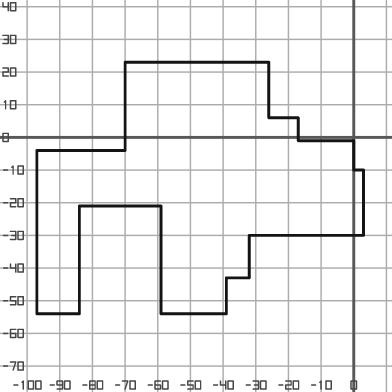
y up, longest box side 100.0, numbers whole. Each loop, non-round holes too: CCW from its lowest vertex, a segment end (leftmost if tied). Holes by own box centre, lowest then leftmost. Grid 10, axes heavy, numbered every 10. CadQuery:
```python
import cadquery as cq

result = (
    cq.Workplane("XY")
    .moveTo(-97.0, -54.0)
    .lineTo(-84.0, -54.0)
    .lineTo(-84.0, -21.0)
    .lineTo(-59.0, -21.0)
    .lineTo(-59.0, -54.0)
    .lineTo(-39.0, -54.0)
    .lineTo(-39.0, -43.0)
    .lineTo(-32.0, -43.0)
    .lineTo(-32.0, -30.0)
    .lineTo(3.0, -30.0)
    .lineTo(3.0, -10.0)
    .lineTo(0.0, -10.0)
    .lineTo(0.0, -1.0)
    .lineTo(-17.0, -1.0)
    .lineTo(-17.0, 6.0)
    .lineTo(-26.0, 6.0)
    .lineTo(-26.0, 23.0)
    .lineTo(-70.0, 23.0)
    .lineTo(-70.0, -4.0)
    .lineTo(-97.0, -4.0)
    .close()
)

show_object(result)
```